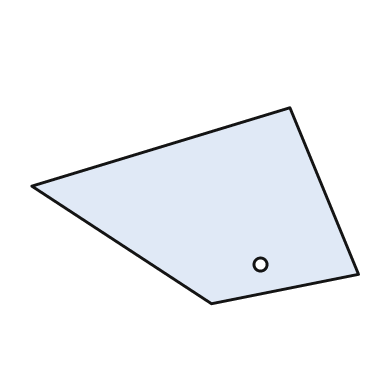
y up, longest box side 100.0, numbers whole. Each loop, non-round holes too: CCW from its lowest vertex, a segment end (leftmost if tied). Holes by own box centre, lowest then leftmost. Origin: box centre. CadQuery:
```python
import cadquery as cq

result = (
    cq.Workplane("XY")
    .moveTo(5.0, -30.0)
    .lineTo(50.0, -21.0)
    .lineTo(29.0, 30.0)
    .lineTo(-50.0, 6.0)
    .close()
    .moveTo(20.0, -18.0)
    .circle(2.0)
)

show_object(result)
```